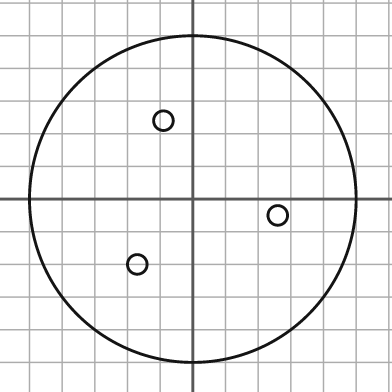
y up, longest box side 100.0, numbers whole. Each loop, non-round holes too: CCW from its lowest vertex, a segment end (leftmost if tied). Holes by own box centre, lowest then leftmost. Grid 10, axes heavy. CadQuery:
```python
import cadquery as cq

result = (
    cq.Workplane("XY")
    .moveTo(0.0, 0.0)
    .circle(50.0)
    .moveTo(-17.0, -20.0)
    .circle(3.0)
    .moveTo(26.0, -5.0)
    .circle(3.0)
    .moveTo(-9.0, 24.0)
    .circle(3.0)
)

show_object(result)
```